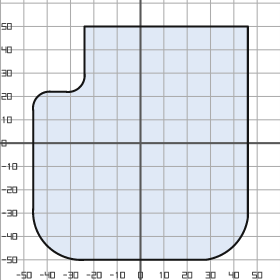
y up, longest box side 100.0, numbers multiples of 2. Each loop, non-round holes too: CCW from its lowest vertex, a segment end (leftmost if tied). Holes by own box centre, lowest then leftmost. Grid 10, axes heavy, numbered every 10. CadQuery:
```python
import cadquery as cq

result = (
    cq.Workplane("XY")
    .moveTo(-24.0, -50.0)
    .lineTo(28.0, -50.0)
    .threePointArc((40.0, -44.0), (46.0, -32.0))
    .lineTo(46.0, 50.0)
    .lineTo(-24.0, 50.0)
    .lineTo(-24.0, 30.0)
    .threePointArc((-26.0, 24.0), (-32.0, 22.0))
    .lineTo(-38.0, 22.0)
    .threePointArc((-44.0, 20.0), (-46.0, 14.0))
    .lineTo(-46.0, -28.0)
    .threePointArc((-40.0, -44.0), (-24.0, -50.0))
    .close()
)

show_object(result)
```